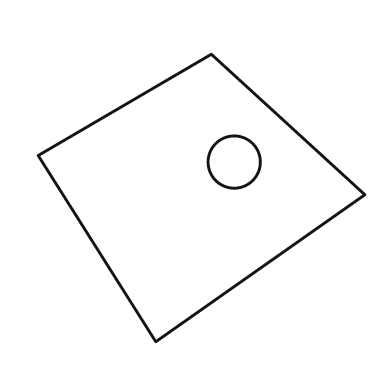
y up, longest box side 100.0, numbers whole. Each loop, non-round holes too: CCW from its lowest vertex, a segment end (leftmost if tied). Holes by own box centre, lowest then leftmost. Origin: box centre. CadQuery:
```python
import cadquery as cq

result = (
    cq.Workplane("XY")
    .moveTo(-14.0, -44.0)
    .lineTo(50.0, 1.0)
    .lineTo(3.0, 44.0)
    .lineTo(-50.0, 13.0)
    .close()
    .moveTo(10.0, 11.0)
    .circle(8.0)
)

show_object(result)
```